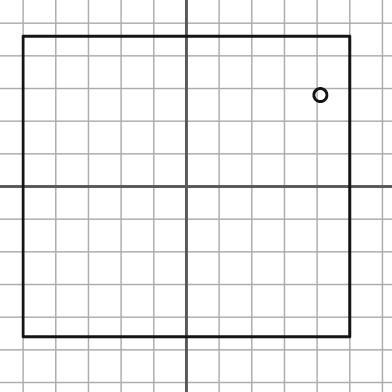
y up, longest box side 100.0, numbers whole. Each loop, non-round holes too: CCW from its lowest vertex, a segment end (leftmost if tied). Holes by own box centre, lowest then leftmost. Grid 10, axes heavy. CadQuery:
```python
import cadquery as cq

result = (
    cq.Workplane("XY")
    .moveTo(-50.0, -46.0)
    .lineTo(50.0, -46.0)
    .lineTo(50.0, 46.0)
    .lineTo(-50.0, 46.0)
    .close()
    .moveTo(41.0, 28.0)
    .circle(2.0)
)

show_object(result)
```